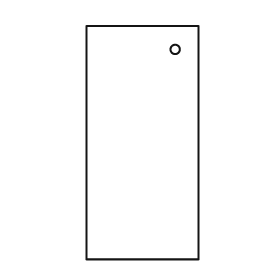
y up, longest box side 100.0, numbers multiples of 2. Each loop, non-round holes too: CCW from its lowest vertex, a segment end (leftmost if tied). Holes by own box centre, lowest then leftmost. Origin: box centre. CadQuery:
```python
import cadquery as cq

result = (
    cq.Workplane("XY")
    .moveTo(-24.0, -50.0)
    .lineTo(24.0, -50.0)
    .lineTo(24.0, 50.0)
    .lineTo(-24.0, 50.0)
    .close()
    .moveTo(14.0, 40.0)
    .circle(2.0)
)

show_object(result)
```